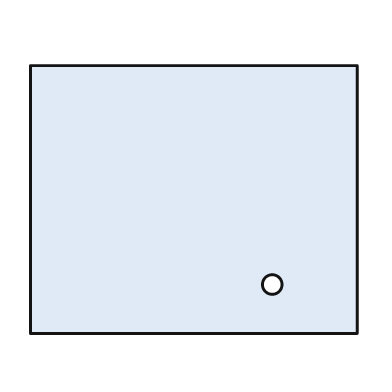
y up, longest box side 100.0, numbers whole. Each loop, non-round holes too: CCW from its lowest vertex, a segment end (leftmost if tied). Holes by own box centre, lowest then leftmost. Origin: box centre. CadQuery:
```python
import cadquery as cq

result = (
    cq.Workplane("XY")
    .moveTo(-50.0, -41.0)
    .lineTo(50.0, -41.0)
    .lineTo(50.0, 41.0)
    .lineTo(-50.0, 41.0)
    .close()
    .moveTo(24.0, -26.0)
    .circle(3.0)
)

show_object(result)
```